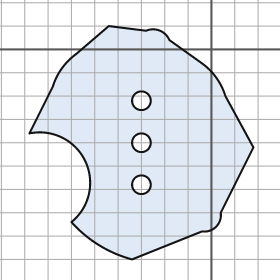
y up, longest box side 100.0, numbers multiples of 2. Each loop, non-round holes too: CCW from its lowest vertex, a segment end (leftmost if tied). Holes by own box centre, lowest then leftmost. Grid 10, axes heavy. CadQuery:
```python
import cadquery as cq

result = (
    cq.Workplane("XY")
    .moveTo(-34.0, -90.0)
    .lineTo(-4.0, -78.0)
    .threePointArc((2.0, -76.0), (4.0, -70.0))
    .lineTo(18.0, -42.0)
    .lineTo(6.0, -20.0)
    .threePointArc((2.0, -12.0), (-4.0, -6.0))
    .lineTo(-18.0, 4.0)
    .threePointArc((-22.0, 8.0), (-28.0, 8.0))
    .lineTo(-44.0, 10.0)
    .lineTo(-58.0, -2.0)
    .threePointArc((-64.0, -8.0), (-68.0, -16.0))
    .lineTo(-78.0, -36.0)
    .threePointArc((-54.0, -48.0), (-60.0, -74.0))
    .threePointArc((-48.0, -84.0), (-34.0, -90.0))
    .close()
    .moveTo(-30.0, -58.0)
    .circle(4.0)
    .moveTo(-30.0, -40.0)
    .circle(4.0)
    .moveTo(-30.0, -22.0)
    .circle(4.0)
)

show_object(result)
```